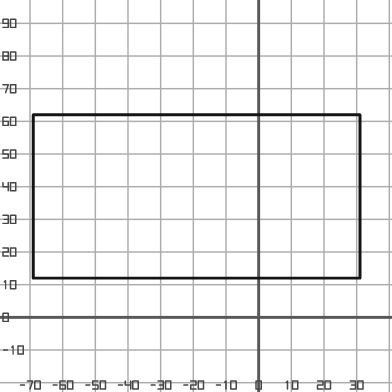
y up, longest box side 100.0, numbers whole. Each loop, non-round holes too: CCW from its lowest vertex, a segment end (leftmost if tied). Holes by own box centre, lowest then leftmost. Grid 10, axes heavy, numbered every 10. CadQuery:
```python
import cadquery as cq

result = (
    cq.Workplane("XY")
    .moveTo(-69.0, 12.0)
    .lineTo(31.0, 12.0)
    .lineTo(31.0, 62.0)
    .lineTo(-69.0, 62.0)
    .close()
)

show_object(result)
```